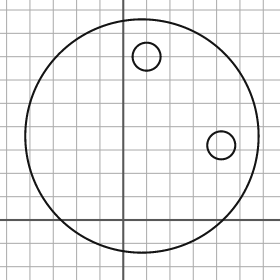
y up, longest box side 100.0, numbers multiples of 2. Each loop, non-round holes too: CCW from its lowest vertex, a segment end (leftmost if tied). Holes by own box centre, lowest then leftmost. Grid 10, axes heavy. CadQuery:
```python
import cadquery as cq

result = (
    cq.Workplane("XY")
    .moveTo(8.0, 36.0)
    .circle(50.0)
    .moveTo(42.0, 32.0)
    .circle(6.0)
    .moveTo(10.0, 70.0)
    .circle(6.0)
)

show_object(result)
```